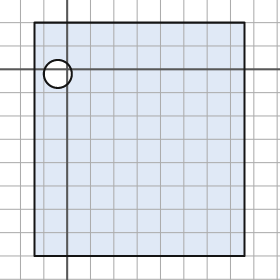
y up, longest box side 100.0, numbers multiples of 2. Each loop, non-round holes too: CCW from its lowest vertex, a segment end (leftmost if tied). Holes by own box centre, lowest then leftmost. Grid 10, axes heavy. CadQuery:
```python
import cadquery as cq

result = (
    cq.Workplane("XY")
    .moveTo(-14.0, -80.0)
    .lineTo(76.0, -80.0)
    .lineTo(76.0, 20.0)
    .lineTo(-14.0, 20.0)
    .close()
    .moveTo(-4.0, -2.0)
    .circle(6.0)
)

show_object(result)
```